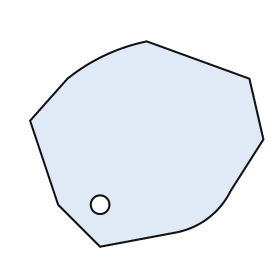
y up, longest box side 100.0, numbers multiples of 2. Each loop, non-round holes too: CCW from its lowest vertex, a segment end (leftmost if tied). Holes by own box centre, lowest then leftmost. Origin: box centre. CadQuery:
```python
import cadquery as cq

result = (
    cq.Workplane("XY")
    .moveTo(-20.0, -44.0)
    .lineTo(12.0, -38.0)
    .threePointArc((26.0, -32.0), (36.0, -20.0))
    .lineTo(50.0, 2.0)
    .lineTo(44.0, 28.0)
    .lineTo(0.0, 44.0)
    .threePointArc((-18.0, 38.0), (-34.0, 28.0))
    .lineTo(-50.0, 10.0)
    .lineTo(-38.0, -26.0)
    .close()
    .moveTo(-20.0, -26.0)
    .circle(4.0)
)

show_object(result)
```